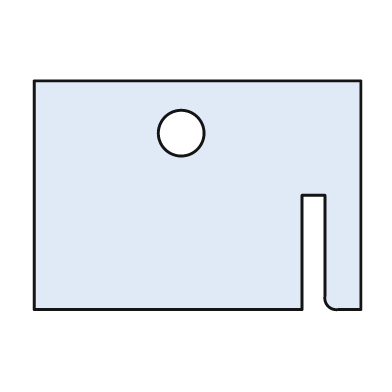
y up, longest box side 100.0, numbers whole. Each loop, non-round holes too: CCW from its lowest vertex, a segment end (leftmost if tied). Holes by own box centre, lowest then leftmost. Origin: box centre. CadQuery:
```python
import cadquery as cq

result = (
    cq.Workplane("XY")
    .moveTo(-50.0, -35.0)
    .lineTo(32.0, -35.0)
    .lineTo(32.0, 0.0)
    .lineTo(39.0, 0.0)
    .lineTo(39.0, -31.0)
    .threePointArc((40.0, -34.0), (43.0, -35.0))
    .lineTo(50.0, -35.0)
    .lineTo(50.0, 35.0)
    .lineTo(-50.0, 35.0)
    .close()
    .moveTo(-5.0, 19.0)
    .circle(7.0)
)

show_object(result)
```